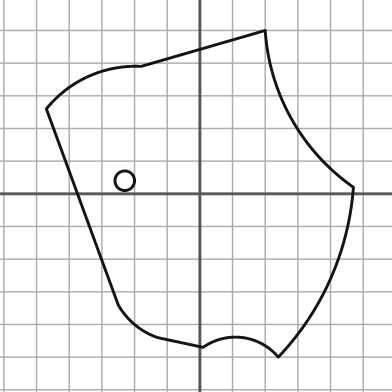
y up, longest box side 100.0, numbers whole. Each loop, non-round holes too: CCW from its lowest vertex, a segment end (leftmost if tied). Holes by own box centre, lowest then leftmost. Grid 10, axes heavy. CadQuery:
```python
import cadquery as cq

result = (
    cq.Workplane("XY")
    .moveTo(24.0, -50.0)
    .threePointArc((40.0, -26.0), (47.0, 2.0))
    .threePointArc((28.0, 23.0), (20.0, 50.0))
    .lineTo(-18.0, 39.0)
    .threePointArc((-34.0, 36.0), (-47.0, 26.0))
    .lineTo(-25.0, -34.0)
    .threePointArc((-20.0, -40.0), (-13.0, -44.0))
    .lineTo(1.0, -47.0)
    .threePointArc((13.0, -44.0), (24.0, -50.0))
    .close()
    .moveTo(-23.0, 4.0)
    .circle(3.0)
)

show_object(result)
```